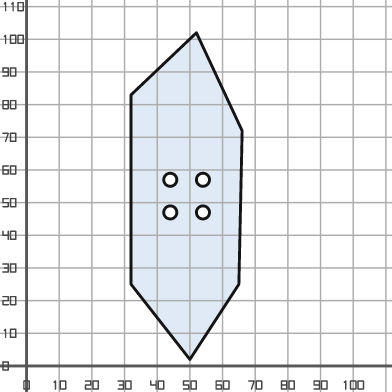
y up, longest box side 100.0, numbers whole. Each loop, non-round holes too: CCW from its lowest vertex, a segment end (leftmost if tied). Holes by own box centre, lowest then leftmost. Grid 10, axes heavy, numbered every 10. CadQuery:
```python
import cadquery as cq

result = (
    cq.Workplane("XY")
    .moveTo(50.0, 2.0)
    .lineTo(65.0, 25.0)
    .lineTo(66.0, 72.0)
    .lineTo(52.0, 102.0)
    .lineTo(32.0, 83.0)
    .lineTo(32.0, 25.0)
    .close()
    .moveTo(44.0, 47.0)
    .circle(2.0)
    .moveTo(54.0, 47.0)
    .circle(2.0)
    .moveTo(44.0, 57.0)
    .circle(2.0)
    .moveTo(54.0, 57.0)
    .circle(2.0)
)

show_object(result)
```